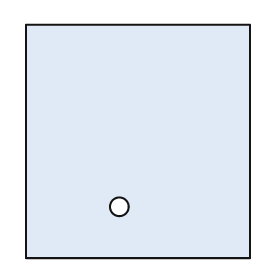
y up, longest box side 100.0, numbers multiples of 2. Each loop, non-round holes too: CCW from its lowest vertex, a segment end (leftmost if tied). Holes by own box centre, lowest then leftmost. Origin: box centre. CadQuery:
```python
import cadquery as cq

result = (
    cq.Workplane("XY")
    .moveTo(-48.0, -50.0)
    .lineTo(48.0, -50.0)
    .lineTo(48.0, 50.0)
    .lineTo(-48.0, 50.0)
    .close()
    .moveTo(-8.0, -28.0)
    .circle(4.0)
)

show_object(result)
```